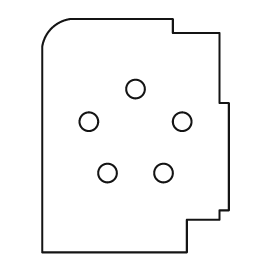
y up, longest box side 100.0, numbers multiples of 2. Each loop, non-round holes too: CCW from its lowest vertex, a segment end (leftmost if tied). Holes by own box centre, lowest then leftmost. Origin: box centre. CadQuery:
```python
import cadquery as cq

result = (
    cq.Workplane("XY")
    .moveTo(-40.0, -50.0)
    .lineTo(22.0, -50.0)
    .lineTo(22.0, -36.0)
    .lineTo(36.0, -36.0)
    .lineTo(36.0, -32.0)
    .lineTo(40.0, -32.0)
    .lineTo(40.0, 14.0)
    .lineTo(36.0, 14.0)
    .lineTo(36.0, 44.0)
    .lineTo(16.0, 44.0)
    .lineTo(16.0, 50.0)
    .lineTo(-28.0, 50.0)
    .threePointArc((-36.0, 46.0), (-40.0, 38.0))
    .close()
    .moveTo(-12.0, -16.0)
    .circle(4.0)
    .moveTo(12.0, -16.0)
    .circle(4.0)
    .moveTo(-20.0, 6.0)
    .circle(4.0)
    .moveTo(20.0, 6.0)
    .circle(4.0)
    .moveTo(0.0, 20.0)
    .circle(4.0)
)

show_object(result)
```